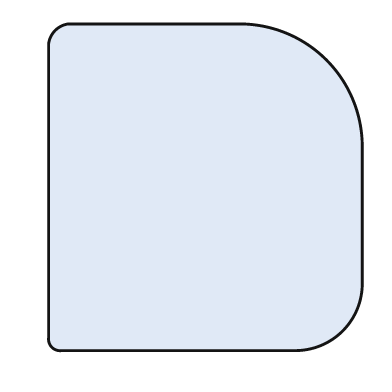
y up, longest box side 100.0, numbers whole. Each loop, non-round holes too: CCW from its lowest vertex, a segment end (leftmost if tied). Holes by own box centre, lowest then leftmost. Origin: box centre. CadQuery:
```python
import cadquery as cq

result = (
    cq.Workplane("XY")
    .moveTo(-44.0, -50.0)
    .lineTo(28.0, -50.0)
    .threePointArc((42.0, -44.0), (48.0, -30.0))
    .lineTo(48.0, 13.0)
    .threePointArc((37.0, 39.0), (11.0, 50.0))
    .lineTo(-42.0, 50.0)
    .threePointArc((-46.0, 48.0), (-48.0, 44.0))
    .lineTo(-48.0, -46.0)
    .threePointArc((-47.0, -49.0), (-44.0, -50.0))
    .close()
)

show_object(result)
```